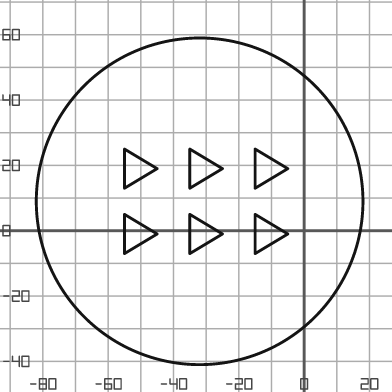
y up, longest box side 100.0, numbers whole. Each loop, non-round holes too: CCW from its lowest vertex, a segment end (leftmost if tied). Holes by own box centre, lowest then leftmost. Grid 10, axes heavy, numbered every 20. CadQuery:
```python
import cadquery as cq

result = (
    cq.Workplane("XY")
    .moveTo(-32.0, 9.0)
    .circle(50.0)
    .moveTo(-55.0, -7.0)
    .lineTo(-45.0, -1.0)
    .lineTo(-55.0, 5.0)
    .close()
    .moveTo(-35.0, -7.0)
    .lineTo(-25.0, -1.0)
    .lineTo(-35.0, 5.0)
    .close()
    .moveTo(-15.0, -7.0)
    .lineTo(-5.0, -1.0)
    .lineTo(-15.0, 5.0)
    .close()
    .moveTo(-55.0, 13.0)
    .lineTo(-45.0, 19.0)
    .lineTo(-55.0, 25.0)
    .close()
    .moveTo(-35.0, 13.0)
    .lineTo(-25.0, 19.0)
    .lineTo(-35.0, 25.0)
    .close()
    .moveTo(-15.0, 13.0)
    .lineTo(-5.0, 19.0)
    .lineTo(-15.0, 25.0)
    .close()
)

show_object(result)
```